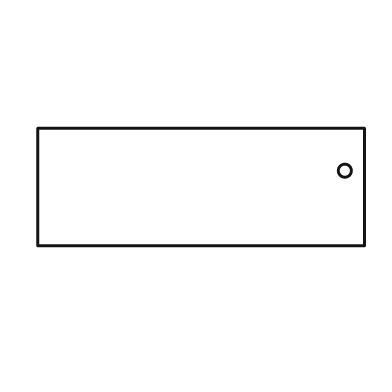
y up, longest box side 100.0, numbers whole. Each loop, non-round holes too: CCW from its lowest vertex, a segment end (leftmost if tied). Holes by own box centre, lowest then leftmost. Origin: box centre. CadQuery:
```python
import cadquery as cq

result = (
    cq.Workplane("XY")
    .moveTo(-50.0, -18.0)
    .lineTo(50.0, -18.0)
    .lineTo(50.0, 18.0)
    .lineTo(-50.0, 18.0)
    .close()
    .moveTo(44.0, 5.0)
    .circle(2.0)
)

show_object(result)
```